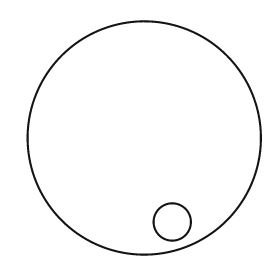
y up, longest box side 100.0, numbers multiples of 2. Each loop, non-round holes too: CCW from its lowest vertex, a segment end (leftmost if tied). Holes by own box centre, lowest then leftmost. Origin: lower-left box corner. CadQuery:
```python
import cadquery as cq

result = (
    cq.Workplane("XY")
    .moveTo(50.0, 50.0)
    .circle(50.0)
    .moveTo(62.0, 14.0)
    .circle(8.0)
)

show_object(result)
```